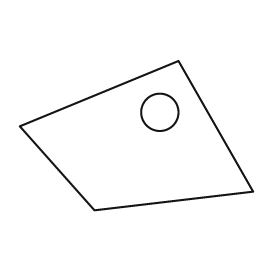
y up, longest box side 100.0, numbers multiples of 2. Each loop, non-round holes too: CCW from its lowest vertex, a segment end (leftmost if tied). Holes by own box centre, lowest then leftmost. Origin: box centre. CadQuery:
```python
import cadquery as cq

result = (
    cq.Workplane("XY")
    .moveTo(-18.0, -32.0)
    .lineTo(50.0, -24.0)
    .lineTo(18.0, 32.0)
    .lineTo(-50.0, 4.0)
    .close()
    .moveTo(10.0, 10.0)
    .circle(8.0)
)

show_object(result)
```